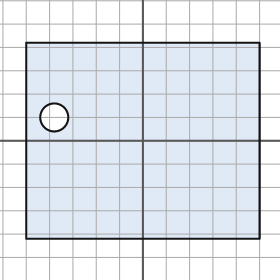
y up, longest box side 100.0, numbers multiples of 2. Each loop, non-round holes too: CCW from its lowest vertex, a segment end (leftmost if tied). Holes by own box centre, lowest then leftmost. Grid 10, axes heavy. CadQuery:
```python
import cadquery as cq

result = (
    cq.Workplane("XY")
    .moveTo(-50.0, -42.0)
    .lineTo(50.0, -42.0)
    .lineTo(50.0, 42.0)
    .lineTo(-50.0, 42.0)
    .close()
    .moveTo(-38.0, 10.0)
    .circle(6.0)
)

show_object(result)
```